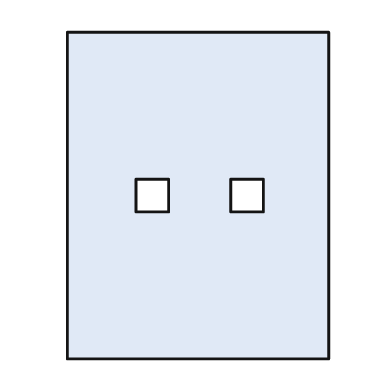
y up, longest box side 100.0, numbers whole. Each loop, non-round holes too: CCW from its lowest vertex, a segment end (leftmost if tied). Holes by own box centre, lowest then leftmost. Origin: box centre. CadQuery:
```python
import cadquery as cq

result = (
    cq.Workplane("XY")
    .moveTo(-40.0, -50.0)
    .lineTo(40.0, -50.0)
    .lineTo(40.0, 50.0)
    .lineTo(-40.0, 50.0)
    .close()
    .moveTo(-19.0, -5.0)
    .lineTo(-9.0, -5.0)
    .lineTo(-9.0, 5.0)
    .lineTo(-19.0, 5.0)
    .close()
    .moveTo(10.0, -5.0)
    .lineTo(20.0, -5.0)
    .lineTo(20.0, 5.0)
    .lineTo(10.0, 5.0)
    .close()
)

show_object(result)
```